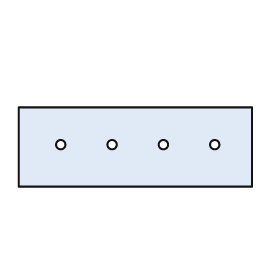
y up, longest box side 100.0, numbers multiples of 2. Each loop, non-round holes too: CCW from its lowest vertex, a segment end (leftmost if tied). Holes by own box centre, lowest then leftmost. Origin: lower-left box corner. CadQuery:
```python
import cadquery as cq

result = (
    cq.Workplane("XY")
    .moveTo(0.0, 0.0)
    .lineTo(100.0, 0.0)
    .lineTo(100.0, 34.0)
    .lineTo(0.0, 34.0)
    .close()
    .moveTo(18.0, 18.0)
    .circle(2.0)
    .moveTo(40.0, 18.0)
    .circle(2.0)
    .moveTo(62.0, 18.0)
    .circle(2.0)
    .moveTo(84.0, 18.0)
    .circle(2.0)
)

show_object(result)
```